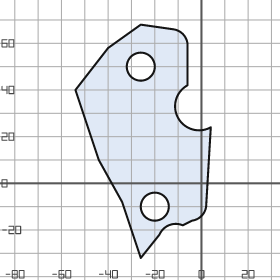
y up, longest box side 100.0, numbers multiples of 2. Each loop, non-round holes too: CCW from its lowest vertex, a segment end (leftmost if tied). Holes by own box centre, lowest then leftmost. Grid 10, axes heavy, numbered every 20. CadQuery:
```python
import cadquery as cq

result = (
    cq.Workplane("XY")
    .moveTo(-26.0, -32.0)
    .lineTo(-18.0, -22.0)
    .threePointArc((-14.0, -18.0), (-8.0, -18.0))
    .lineTo(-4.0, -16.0)
    .threePointArc((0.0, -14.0), (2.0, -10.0))
    .lineTo(4.0, 24.0)
    .threePointArc((-10.0, 28.0), (-6.0, 42.0))
    .lineTo(-6.0, 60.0)
    .threePointArc((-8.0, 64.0), (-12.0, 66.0))
    .lineTo(-26.0, 68.0)
    .lineTo(-40.0, 58.0)
    .lineTo(-54.0, 40.0)
    .lineTo(-44.0, 10.0)
    .lineTo(-34.0, -8.0)
    .close()
    .moveTo(-20.0, -10.0)
    .circle(6.0)
    .moveTo(-26.0, 50.0)
    .circle(6.0)
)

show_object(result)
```